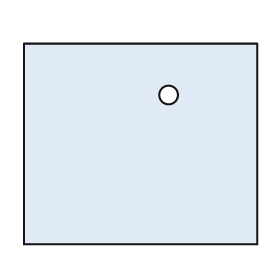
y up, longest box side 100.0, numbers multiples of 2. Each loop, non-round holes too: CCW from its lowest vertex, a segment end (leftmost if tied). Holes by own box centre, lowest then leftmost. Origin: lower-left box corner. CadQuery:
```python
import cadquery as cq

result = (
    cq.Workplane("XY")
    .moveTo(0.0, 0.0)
    .lineTo(100.0, 0.0)
    .lineTo(100.0, 86.0)
    .lineTo(0.0, 86.0)
    .close()
    .moveTo(62.0, 64.0)
    .circle(4.0)
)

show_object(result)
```